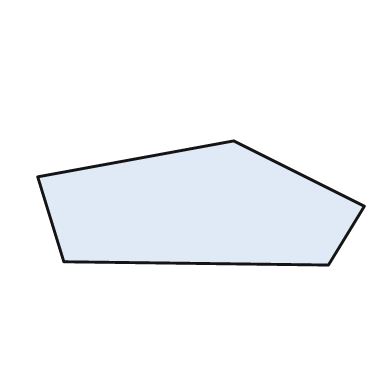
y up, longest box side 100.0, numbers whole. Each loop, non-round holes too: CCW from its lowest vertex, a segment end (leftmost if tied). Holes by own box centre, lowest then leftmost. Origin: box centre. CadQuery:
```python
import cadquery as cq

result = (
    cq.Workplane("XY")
    .moveTo(39.0, -19.0)
    .lineTo(50.0, -1.0)
    .lineTo(10.0, 19.0)
    .lineTo(-50.0, 8.0)
    .lineTo(-42.0, -18.0)
    .close()
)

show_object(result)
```